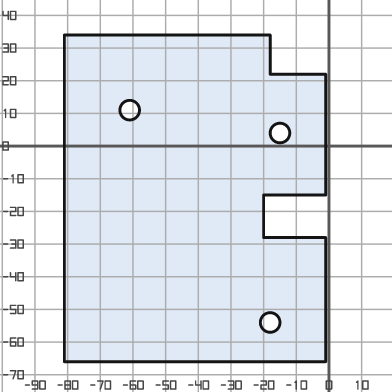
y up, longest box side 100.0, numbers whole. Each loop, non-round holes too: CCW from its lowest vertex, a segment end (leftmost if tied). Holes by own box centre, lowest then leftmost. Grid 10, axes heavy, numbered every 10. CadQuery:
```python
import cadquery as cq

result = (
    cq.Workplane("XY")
    .moveTo(-81.0, -66.0)
    .lineTo(-1.0, -66.0)
    .lineTo(-1.0, -28.0)
    .lineTo(-20.0, -28.0)
    .lineTo(-20.0, -15.0)
    .lineTo(-1.0, -15.0)
    .lineTo(-1.0, 22.0)
    .lineTo(-18.0, 22.0)
    .lineTo(-18.0, 34.0)
    .lineTo(-81.0, 34.0)
    .close()
    .moveTo(-18.0, -54.0)
    .circle(3.0)
    .moveTo(-15.0, 4.0)
    .circle(3.0)
    .moveTo(-61.0, 11.0)
    .circle(3.0)
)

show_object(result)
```